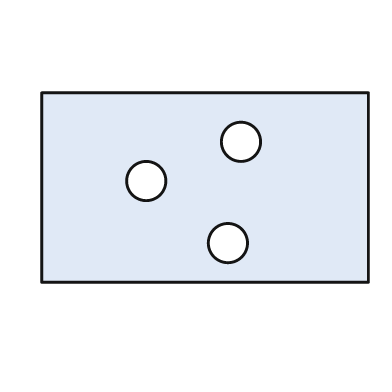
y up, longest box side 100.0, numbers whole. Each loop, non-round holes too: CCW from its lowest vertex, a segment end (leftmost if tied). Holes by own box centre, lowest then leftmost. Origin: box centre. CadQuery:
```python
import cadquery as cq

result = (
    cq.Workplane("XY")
    .moveTo(-50.0, -29.0)
    .lineTo(50.0, -29.0)
    .lineTo(50.0, 29.0)
    .lineTo(-50.0, 29.0)
    .close()
    .moveTo(7.0, -17.0)
    .circle(6.0)
    .moveTo(-18.0, 2.0)
    .circle(6.0)
    .moveTo(11.0, 14.0)
    .circle(6.0)
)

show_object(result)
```